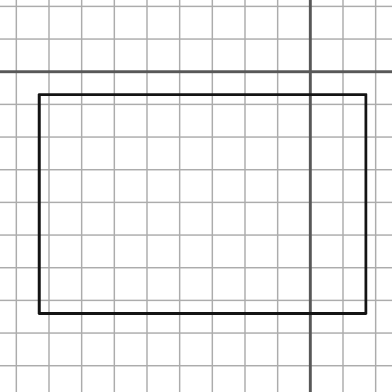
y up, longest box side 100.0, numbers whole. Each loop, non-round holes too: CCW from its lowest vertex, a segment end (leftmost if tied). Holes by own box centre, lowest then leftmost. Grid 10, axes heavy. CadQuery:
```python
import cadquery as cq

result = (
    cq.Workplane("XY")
    .moveTo(-83.0, -74.0)
    .lineTo(17.0, -74.0)
    .lineTo(17.0, -7.0)
    .lineTo(-83.0, -7.0)
    .close()
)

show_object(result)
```